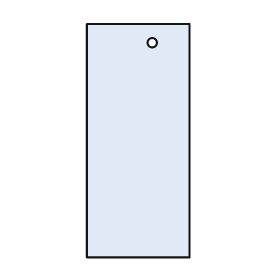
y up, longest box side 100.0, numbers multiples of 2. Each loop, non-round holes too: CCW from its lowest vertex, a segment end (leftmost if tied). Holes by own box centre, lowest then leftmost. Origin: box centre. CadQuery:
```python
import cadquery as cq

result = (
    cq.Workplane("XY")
    .moveTo(-22.0, -50.0)
    .lineTo(22.0, -50.0)
    .lineTo(22.0, 50.0)
    .lineTo(-22.0, 50.0)
    .close()
    .moveTo(6.0, 42.0)
    .circle(2.0)
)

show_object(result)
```